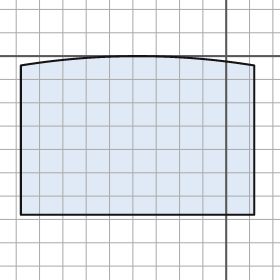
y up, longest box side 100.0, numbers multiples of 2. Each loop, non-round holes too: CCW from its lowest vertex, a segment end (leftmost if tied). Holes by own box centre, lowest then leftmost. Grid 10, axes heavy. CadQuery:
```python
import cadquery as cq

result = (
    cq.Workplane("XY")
    .moveTo(-88.0, -68.0)
    .lineTo(12.0, -68.0)
    .lineTo(12.0, -4.0)
    .threePointArc((-38.0, 0.0), (-88.0, -4.0))
    .close()
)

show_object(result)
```